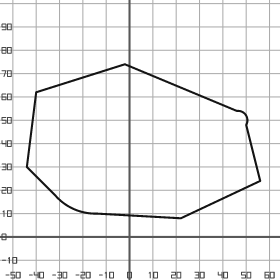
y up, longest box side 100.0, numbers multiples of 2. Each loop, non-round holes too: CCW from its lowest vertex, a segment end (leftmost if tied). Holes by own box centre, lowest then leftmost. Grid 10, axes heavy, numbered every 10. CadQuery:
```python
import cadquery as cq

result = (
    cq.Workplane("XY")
    .moveTo(22.0, 8.0)
    .lineTo(56.0, 24.0)
    .lineTo(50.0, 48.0)
    .threePointArc((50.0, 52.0), (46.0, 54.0))
    .lineTo(-2.0, 74.0)
    .lineTo(-40.0, 62.0)
    .lineTo(-44.0, 30.0)
    .lineTo(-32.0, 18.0)
    .threePointArc((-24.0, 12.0), (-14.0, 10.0))
    .close()
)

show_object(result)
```